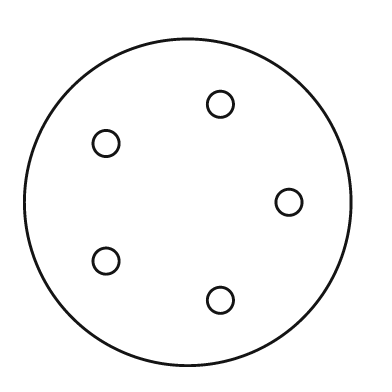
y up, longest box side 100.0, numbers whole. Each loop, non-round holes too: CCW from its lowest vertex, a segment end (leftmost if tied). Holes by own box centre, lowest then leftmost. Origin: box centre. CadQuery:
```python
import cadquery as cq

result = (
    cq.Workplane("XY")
    .moveTo(0.0, 0.0)
    .circle(50.0)
    .moveTo(10.0, -30.0)
    .circle(4.0)
    .moveTo(-25.0, -18.0)
    .circle(4.0)
    .moveTo(31.0, 0.0)
    .circle(4.0)
    .moveTo(-25.0, 18.0)
    .circle(4.0)
    .moveTo(10.0, 30.0)
    .circle(4.0)
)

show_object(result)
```